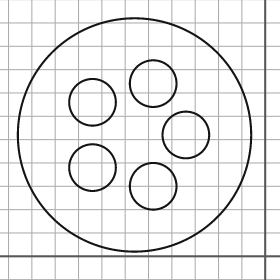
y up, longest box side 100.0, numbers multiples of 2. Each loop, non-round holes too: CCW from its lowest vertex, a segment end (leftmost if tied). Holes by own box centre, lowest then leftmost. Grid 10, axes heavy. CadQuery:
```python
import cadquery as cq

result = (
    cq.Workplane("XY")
    .moveTo(-56.0, 52.0)
    .circle(50.0)
    .moveTo(-48.0, 30.0)
    .circle(10.0)
    .moveTo(-74.0, 38.0)
    .circle(10.0)
    .moveTo(-34.0, 52.0)
    .circle(10.0)
    .moveTo(-74.0, 66.0)
    .circle(10.0)
    .moveTo(-48.0, 74.0)
    .circle(10.0)
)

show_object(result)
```